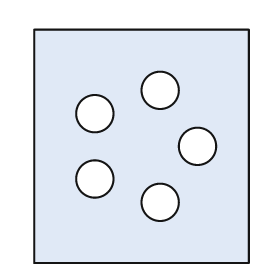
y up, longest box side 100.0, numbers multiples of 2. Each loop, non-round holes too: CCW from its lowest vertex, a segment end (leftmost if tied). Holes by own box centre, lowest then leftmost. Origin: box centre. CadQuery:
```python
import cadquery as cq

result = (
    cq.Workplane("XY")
    .moveTo(-46.0, -50.0)
    .lineTo(46.0, -50.0)
    .lineTo(46.0, 50.0)
    .lineTo(-46.0, 50.0)
    .close()
    .moveTo(8.0, -24.0)
    .circle(8.0)
    .moveTo(-20.0, -14.0)
    .circle(8.0)
    .moveTo(24.0, 0.0)
    .circle(8.0)
    .moveTo(-20.0, 14.0)
    .circle(8.0)
    .moveTo(8.0, 24.0)
    .circle(8.0)
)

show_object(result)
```